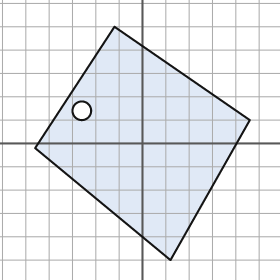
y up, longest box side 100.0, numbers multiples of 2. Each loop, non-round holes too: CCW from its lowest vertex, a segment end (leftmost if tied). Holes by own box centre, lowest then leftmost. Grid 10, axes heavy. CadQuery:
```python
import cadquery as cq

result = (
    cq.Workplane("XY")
    .moveTo(12.0, -50.0)
    .lineTo(46.0, 10.0)
    .lineTo(-12.0, 50.0)
    .lineTo(-46.0, -2.0)
    .close()
    .moveTo(-26.0, 14.0)
    .circle(4.0)
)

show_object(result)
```